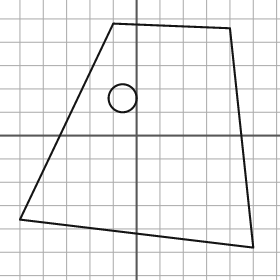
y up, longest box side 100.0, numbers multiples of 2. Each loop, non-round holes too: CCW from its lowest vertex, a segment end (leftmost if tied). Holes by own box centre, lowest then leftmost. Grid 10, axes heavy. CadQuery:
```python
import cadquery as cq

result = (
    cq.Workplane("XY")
    .moveTo(50.0, -48.0)
    .lineTo(40.0, 46.0)
    .lineTo(-10.0, 48.0)
    .lineTo(-50.0, -36.0)
    .close()
    .moveTo(-6.0, 16.0)
    .circle(6.0)
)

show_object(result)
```